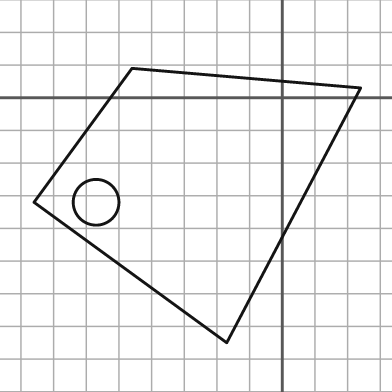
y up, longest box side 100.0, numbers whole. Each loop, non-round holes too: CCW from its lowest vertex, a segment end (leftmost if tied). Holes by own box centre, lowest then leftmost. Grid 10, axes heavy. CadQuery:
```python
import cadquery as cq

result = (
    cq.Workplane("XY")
    .moveTo(-17.0, -75.0)
    .lineTo(24.0, 3.0)
    .lineTo(-46.0, 9.0)
    .lineTo(-76.0, -32.0)
    .close()
    .moveTo(-57.0, -32.0)
    .circle(7.0)
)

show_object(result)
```